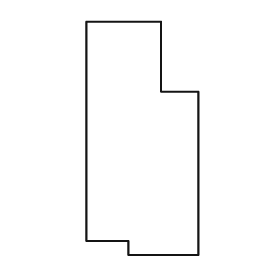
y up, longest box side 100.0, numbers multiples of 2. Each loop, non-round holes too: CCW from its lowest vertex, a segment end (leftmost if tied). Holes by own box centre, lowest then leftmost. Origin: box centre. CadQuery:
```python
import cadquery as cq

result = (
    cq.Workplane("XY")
    .moveTo(-6.0, -50.0)
    .lineTo(24.0, -50.0)
    .lineTo(24.0, 20.0)
    .lineTo(8.0, 20.0)
    .lineTo(8.0, 50.0)
    .lineTo(-24.0, 50.0)
    .lineTo(-24.0, -44.0)
    .lineTo(-6.0, -44.0)
    .close()
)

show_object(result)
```